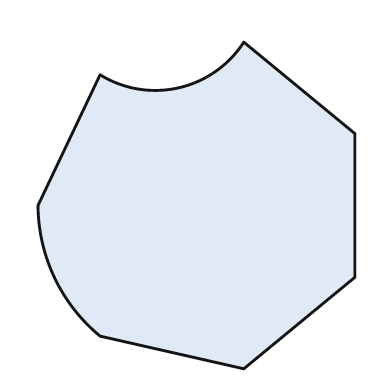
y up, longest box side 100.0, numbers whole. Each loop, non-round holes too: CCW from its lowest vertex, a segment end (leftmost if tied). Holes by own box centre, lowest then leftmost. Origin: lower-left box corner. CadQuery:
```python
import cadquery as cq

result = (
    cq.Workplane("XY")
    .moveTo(63.0, 0.0)
    .lineTo(97.0, 28.0)
    .lineTo(97.0, 72.0)
    .lineTo(63.0, 100.0)
    .threePointArc((43.0, 86.0), (19.0, 90.0))
    .lineTo(0.0, 50.0)
    .threePointArc((5.0, 28.0), (19.0, 10.0))
    .close()
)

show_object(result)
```